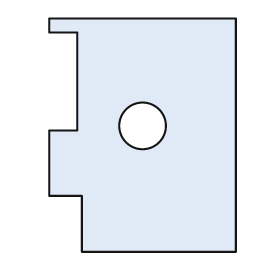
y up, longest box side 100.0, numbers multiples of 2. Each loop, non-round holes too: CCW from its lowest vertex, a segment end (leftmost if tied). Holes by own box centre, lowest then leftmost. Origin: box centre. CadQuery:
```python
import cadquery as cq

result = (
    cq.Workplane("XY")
    .moveTo(-26.0, -50.0)
    .lineTo(40.0, -50.0)
    .lineTo(40.0, 50.0)
    .lineTo(-40.0, 50.0)
    .lineTo(-40.0, 44.0)
    .lineTo(-28.0, 44.0)
    .lineTo(-28.0, 2.0)
    .lineTo(-40.0, 2.0)
    .lineTo(-40.0, -26.0)
    .lineTo(-26.0, -26.0)
    .close()
    .moveTo(0.0, 4.0)
    .circle(10.0)
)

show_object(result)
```